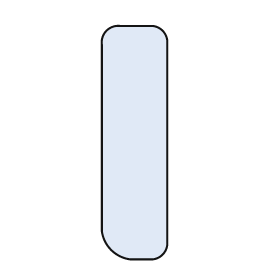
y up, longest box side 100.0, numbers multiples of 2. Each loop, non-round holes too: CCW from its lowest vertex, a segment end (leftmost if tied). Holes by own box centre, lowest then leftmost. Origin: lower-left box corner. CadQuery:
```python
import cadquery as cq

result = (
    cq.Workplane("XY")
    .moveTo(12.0, 0.0)
    .lineTo(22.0, 0.0)
    .threePointArc((26.0, 2.0), (28.0, 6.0))
    .lineTo(28.0, 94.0)
    .threePointArc((26.0, 98.0), (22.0, 100.0))
    .lineTo(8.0, 100.0)
    .threePointArc((2.0, 98.0), (0.0, 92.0))
    .lineTo(0.0, 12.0)
    .threePointArc((4.0, 4.0), (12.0, 0.0))
    .close()
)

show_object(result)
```